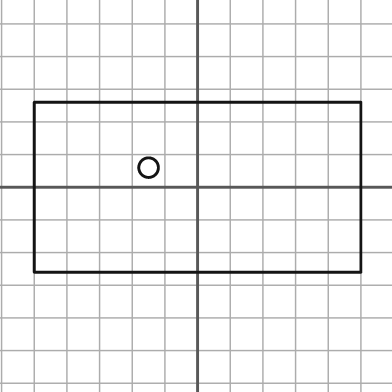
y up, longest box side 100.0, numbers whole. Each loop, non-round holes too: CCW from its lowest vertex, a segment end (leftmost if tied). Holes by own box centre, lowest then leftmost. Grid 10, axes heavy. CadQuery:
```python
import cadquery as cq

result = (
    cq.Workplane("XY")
    .moveTo(-50.0, -26.0)
    .lineTo(50.0, -26.0)
    .lineTo(50.0, 26.0)
    .lineTo(-50.0, 26.0)
    .close()
    .moveTo(-15.0, 6.0)
    .circle(3.0)
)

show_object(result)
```